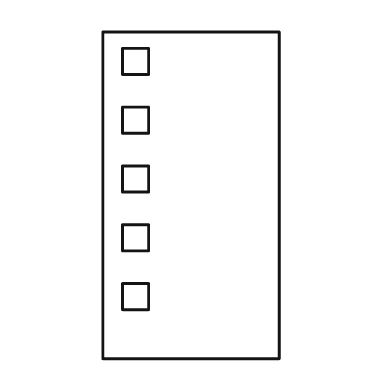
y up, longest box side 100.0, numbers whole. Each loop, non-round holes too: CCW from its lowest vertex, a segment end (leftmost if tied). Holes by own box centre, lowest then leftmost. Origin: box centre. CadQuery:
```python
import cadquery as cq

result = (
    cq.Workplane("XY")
    .moveTo(-27.0, -50.0)
    .lineTo(27.0, -50.0)
    .lineTo(27.0, 50.0)
    .lineTo(-27.0, 50.0)
    .close()
    .moveTo(-21.0, -35.0)
    .lineTo(-13.0, -35.0)
    .lineTo(-13.0, -27.0)
    .lineTo(-21.0, -27.0)
    .close()
    .moveTo(-21.0, -17.0)
    .lineTo(-13.0, -17.0)
    .lineTo(-13.0, -9.0)
    .lineTo(-21.0, -9.0)
    .close()
    .moveTo(-21.0, 1.0)
    .lineTo(-13.0, 1.0)
    .lineTo(-13.0, 9.0)
    .lineTo(-21.0, 9.0)
    .close()
    .moveTo(-21.0, 19.0)
    .lineTo(-13.0, 19.0)
    .lineTo(-13.0, 27.0)
    .lineTo(-21.0, 27.0)
    .close()
    .moveTo(-21.0, 37.0)
    .lineTo(-13.0, 37.0)
    .lineTo(-13.0, 45.0)
    .lineTo(-21.0, 45.0)
    .close()
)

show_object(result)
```